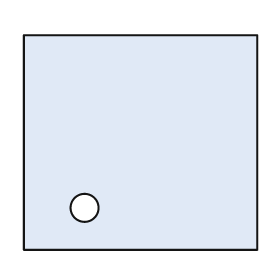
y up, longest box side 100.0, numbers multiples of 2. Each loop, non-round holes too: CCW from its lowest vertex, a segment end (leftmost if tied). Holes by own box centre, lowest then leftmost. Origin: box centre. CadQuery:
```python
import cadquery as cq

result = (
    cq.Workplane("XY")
    .moveTo(-50.0, -46.0)
    .lineTo(50.0, -46.0)
    .lineTo(50.0, 46.0)
    .lineTo(-50.0, 46.0)
    .close()
    .moveTo(-24.0, -28.0)
    .circle(6.0)
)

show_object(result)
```